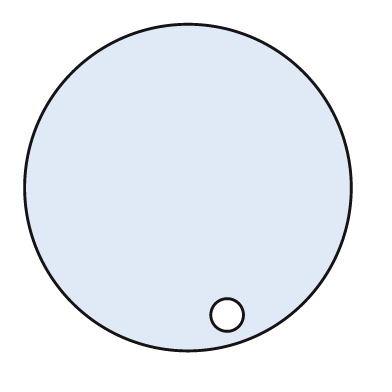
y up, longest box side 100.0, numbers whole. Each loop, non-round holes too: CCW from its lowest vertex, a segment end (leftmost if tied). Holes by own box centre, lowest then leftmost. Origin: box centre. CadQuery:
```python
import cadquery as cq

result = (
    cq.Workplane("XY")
    .moveTo(0.0, 0.0)
    .circle(50.0)
    .moveTo(12.0, -39.0)
    .circle(5.0)
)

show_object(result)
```